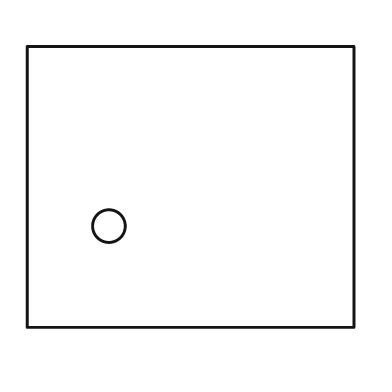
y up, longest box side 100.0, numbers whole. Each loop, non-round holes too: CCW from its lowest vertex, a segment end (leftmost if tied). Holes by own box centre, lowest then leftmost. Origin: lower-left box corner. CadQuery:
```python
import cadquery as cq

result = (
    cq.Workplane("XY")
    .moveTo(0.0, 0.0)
    .lineTo(100.0, 0.0)
    .lineTo(100.0, 86.0)
    .lineTo(0.0, 86.0)
    .close()
    .moveTo(25.0, 31.0)
    .circle(5.0)
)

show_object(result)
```